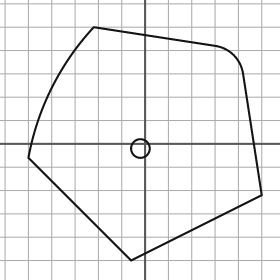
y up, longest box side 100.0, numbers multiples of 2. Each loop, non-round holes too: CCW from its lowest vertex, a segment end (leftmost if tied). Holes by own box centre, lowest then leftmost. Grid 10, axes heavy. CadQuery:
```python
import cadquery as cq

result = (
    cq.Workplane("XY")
    .moveTo(-6.0, -50.0)
    .lineTo(50.0, -22.0)
    .lineTo(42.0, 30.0)
    .threePointArc((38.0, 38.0), (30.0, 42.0))
    .lineTo(-22.0, 50.0)
    .threePointArc((-40.0, 24.0), (-50.0, -6.0))
    .close()
    .moveTo(-2.0, -2.0)
    .circle(4.0)
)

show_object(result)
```